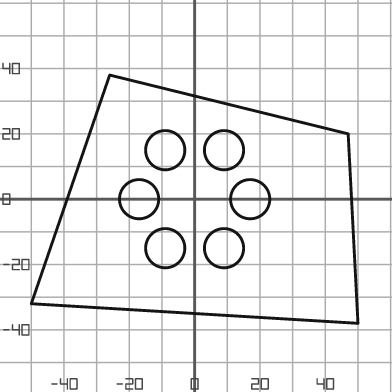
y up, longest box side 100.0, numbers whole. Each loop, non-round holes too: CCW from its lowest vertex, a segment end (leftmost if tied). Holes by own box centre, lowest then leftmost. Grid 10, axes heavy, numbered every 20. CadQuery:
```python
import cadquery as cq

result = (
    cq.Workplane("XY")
    .moveTo(50.0, -38.0)
    .lineTo(47.0, 20.0)
    .lineTo(-26.0, 38.0)
    .lineTo(-50.0, -32.0)
    .close()
    .moveTo(-9.0, -15.0)
    .circle(6.0)
    .moveTo(9.0, -15.0)
    .circle(6.0)
    .moveTo(-17.0, 0.0)
    .circle(6.0)
    .moveTo(17.0, 0.0)
    .circle(6.0)
    .moveTo(-9.0, 15.0)
    .circle(6.0)
    .moveTo(9.0, 15.0)
    .circle(6.0)
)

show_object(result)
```